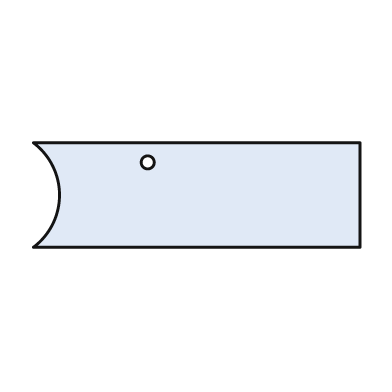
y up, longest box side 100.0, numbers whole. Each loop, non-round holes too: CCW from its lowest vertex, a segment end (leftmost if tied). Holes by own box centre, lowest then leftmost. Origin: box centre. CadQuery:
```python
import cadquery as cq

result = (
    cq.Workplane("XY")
    .moveTo(-50.0, -16.0)
    .lineTo(50.0, -16.0)
    .lineTo(50.0, 16.0)
    .lineTo(-50.0, 16.0)
    .threePointArc((-42.0, 0.0), (-50.0, -16.0))
    .close()
    .moveTo(-15.0, 10.0)
    .circle(2.0)
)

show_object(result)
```